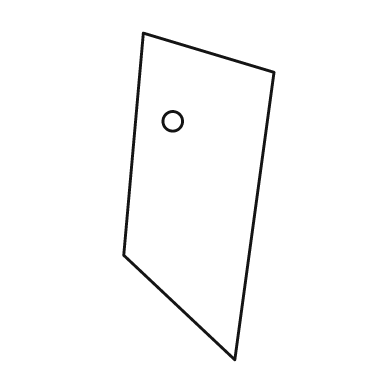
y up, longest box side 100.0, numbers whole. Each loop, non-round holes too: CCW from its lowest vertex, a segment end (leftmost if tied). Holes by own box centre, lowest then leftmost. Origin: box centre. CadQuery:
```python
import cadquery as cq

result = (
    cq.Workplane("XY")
    .moveTo(11.0, -50.0)
    .lineTo(23.0, 38.0)
    .lineTo(-17.0, 50.0)
    .lineTo(-23.0, -18.0)
    .close()
    .moveTo(-8.0, 23.0)
    .circle(3.0)
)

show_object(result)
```